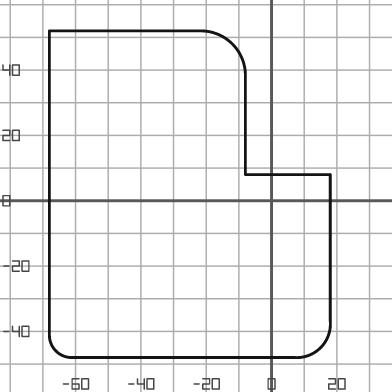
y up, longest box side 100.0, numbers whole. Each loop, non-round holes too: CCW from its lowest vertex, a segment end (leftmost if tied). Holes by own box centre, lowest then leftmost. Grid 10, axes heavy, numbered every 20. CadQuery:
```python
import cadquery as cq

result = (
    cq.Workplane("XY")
    .moveTo(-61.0, -48.0)
    .lineTo(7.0, -48.0)
    .threePointArc((15.0, -45.0), (18.0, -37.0))
    .lineTo(18.0, 8.0)
    .lineTo(-8.0, 8.0)
    .lineTo(-8.0, 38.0)
    .threePointArc((-12.0, 48.0), (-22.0, 52.0))
    .lineTo(-68.0, 52.0)
    .lineTo(-68.0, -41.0)
    .threePointArc((-66.0, -46.0), (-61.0, -48.0))
    .close()
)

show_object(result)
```